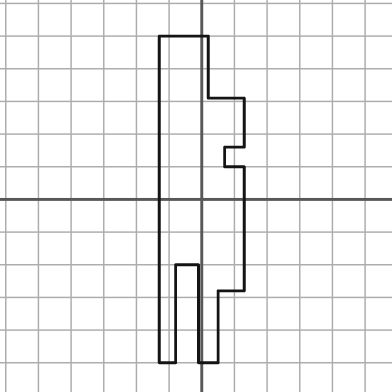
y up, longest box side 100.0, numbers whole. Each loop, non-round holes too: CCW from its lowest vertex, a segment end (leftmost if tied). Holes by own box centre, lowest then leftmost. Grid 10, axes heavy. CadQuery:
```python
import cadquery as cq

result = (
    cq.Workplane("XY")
    .moveTo(-13.0, -50.0)
    .lineTo(-8.0, -50.0)
    .lineTo(-8.0, -20.0)
    .lineTo(-1.0, -20.0)
    .lineTo(-1.0, -50.0)
    .lineTo(5.0, -50.0)
    .lineTo(5.0, -28.0)
    .lineTo(13.0, -28.0)
    .lineTo(13.0, 10.0)
    .lineTo(7.0, 10.0)
    .lineTo(7.0, 16.0)
    .lineTo(13.0, 16.0)
    .lineTo(13.0, 31.0)
    .lineTo(2.0, 31.0)
    .lineTo(2.0, 50.0)
    .lineTo(-13.0, 50.0)
    .close()
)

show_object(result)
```